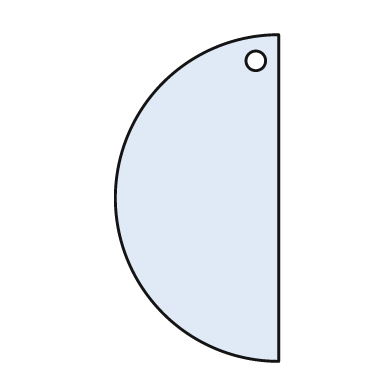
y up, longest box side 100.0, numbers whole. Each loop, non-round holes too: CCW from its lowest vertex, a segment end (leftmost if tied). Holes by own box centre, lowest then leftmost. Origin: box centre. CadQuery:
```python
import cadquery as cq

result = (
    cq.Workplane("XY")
    .moveTo(25.0, -50.0)
    .lineTo(25.0, 50.0)
    .threePointArc((-25.0, 0.0), (25.0, -50.0))
    .close()
    .moveTo(18.0, 42.0)
    .circle(3.0)
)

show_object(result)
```